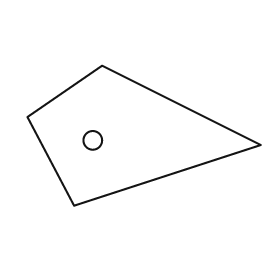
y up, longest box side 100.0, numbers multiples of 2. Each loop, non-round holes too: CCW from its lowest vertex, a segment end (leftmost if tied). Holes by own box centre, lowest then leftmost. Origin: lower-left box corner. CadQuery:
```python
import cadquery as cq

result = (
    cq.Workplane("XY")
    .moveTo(20.0, 0.0)
    .lineTo(100.0, 26.0)
    .lineTo(32.0, 60.0)
    .lineTo(0.0, 38.0)
    .close()
    .moveTo(28.0, 28.0)
    .circle(4.0)
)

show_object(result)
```